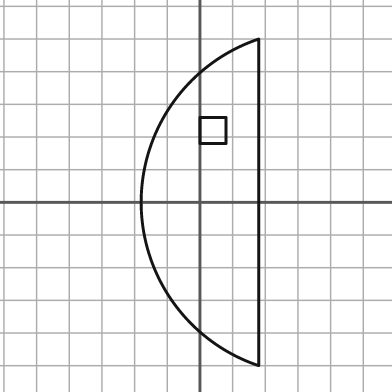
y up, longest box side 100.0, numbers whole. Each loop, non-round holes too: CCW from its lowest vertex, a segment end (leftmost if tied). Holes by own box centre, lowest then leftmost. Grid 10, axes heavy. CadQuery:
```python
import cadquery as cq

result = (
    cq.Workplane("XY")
    .moveTo(18.0, -50.0)
    .lineTo(18.0, 50.0)
    .threePointArc((-18.0, 0.0), (18.0, -50.0))
    .close()
    .moveTo(0.0, 18.0)
    .lineTo(8.0, 18.0)
    .lineTo(8.0, 26.0)
    .lineTo(0.0, 26.0)
    .close()
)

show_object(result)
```